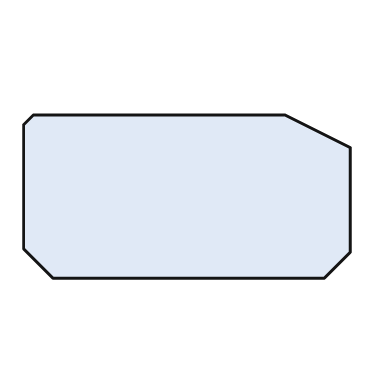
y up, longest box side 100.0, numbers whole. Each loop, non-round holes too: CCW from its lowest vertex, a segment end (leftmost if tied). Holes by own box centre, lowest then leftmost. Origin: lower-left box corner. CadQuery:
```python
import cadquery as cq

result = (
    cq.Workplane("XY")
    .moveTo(9.0, 0.0)
    .lineTo(92.0, 0.0)
    .lineTo(100.0, 8.0)
    .lineTo(100.0, 40.0)
    .lineTo(80.0, 50.0)
    .lineTo(3.0, 50.0)
    .lineTo(0.0, 47.0)
    .lineTo(0.0, 9.0)
    .close()
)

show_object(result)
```